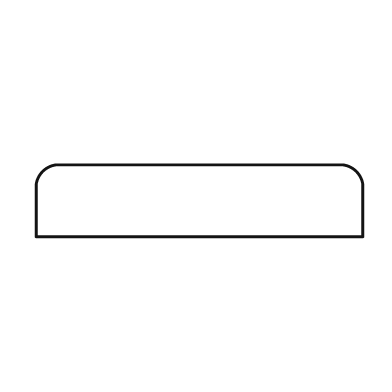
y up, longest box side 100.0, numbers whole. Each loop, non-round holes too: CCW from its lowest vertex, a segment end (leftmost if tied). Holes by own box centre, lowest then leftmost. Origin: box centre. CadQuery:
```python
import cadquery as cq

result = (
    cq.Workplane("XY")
    .moveTo(-50.0, -11.0)
    .lineTo(50.0, -11.0)
    .lineTo(50.0, 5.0)
    .threePointArc((48.0, 9.0), (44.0, 11.0))
    .lineTo(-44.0, 11.0)
    .threePointArc((-48.0, 9.0), (-50.0, 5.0))
    .close()
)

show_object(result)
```